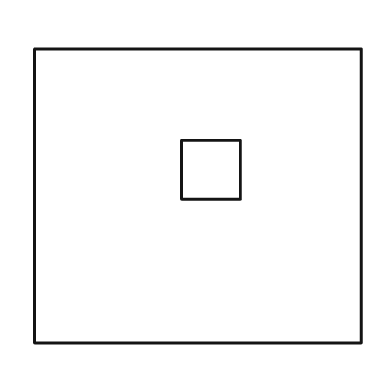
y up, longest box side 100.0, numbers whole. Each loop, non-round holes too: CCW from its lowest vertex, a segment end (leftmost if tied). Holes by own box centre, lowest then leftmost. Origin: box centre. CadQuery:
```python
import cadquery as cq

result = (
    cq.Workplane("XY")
    .moveTo(-50.0, -45.0)
    .lineTo(50.0, -45.0)
    .lineTo(50.0, 45.0)
    .lineTo(-50.0, 45.0)
    .close()
    .moveTo(-5.0, -1.0)
    .lineTo(13.0, -1.0)
    .lineTo(13.0, 17.0)
    .lineTo(-5.0, 17.0)
    .close()
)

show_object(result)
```